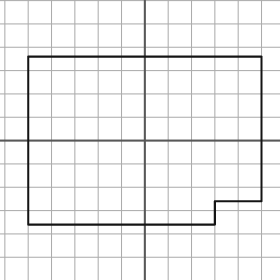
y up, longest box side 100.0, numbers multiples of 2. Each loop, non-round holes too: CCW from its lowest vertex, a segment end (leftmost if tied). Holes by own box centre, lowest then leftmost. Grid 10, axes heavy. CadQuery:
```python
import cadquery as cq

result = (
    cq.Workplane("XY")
    .moveTo(-50.0, -36.0)
    .lineTo(30.0, -36.0)
    .lineTo(30.0, -26.0)
    .lineTo(50.0, -26.0)
    .lineTo(50.0, 36.0)
    .lineTo(-50.0, 36.0)
    .close()
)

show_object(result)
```